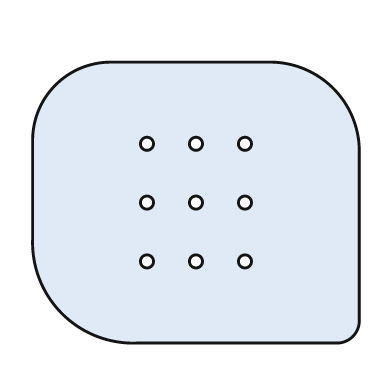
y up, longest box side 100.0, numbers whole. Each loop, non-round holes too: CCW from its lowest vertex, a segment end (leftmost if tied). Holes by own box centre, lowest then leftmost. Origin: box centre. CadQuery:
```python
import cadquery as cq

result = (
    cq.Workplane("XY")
    .moveTo(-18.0, -43.0)
    .lineTo(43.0, -43.0)
    .threePointArc((48.0, -41.0), (50.0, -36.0))
    .lineTo(50.0, 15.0)
    .threePointArc((42.0, 35.0), (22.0, 43.0))
    .lineTo(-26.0, 43.0)
    .threePointArc((-43.0, 36.0), (-50.0, 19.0))
    .lineTo(-50.0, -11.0)
    .threePointArc((-41.0, -34.0), (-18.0, -43.0))
    .close()
    .moveTo(-15.0, -18.0)
    .circle(2.0)
    .moveTo(0.0, -18.0)
    .circle(2.0)
    .moveTo(15.0, -18.0)
    .circle(2.0)
    .moveTo(-15.0, 0.0)
    .circle(2.0)
    .moveTo(0.0, 0.0)
    .circle(2.0)
    .moveTo(15.0, 0.0)
    .circle(2.0)
    .moveTo(-15.0, 18.0)
    .circle(2.0)
    .moveTo(0.0, 18.0)
    .circle(2.0)
    .moveTo(15.0, 18.0)
    .circle(2.0)
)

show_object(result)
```